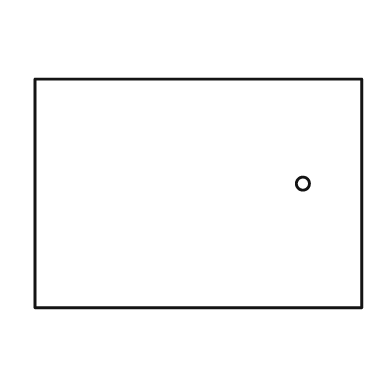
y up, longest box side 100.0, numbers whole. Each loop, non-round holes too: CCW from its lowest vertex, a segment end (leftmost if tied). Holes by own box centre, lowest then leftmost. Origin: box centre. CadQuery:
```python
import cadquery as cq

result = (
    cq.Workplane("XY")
    .moveTo(-50.0, -35.0)
    .lineTo(50.0, -35.0)
    .lineTo(50.0, 35.0)
    .lineTo(-50.0, 35.0)
    .close()
    .moveTo(32.0, 3.0)
    .circle(2.0)
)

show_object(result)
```